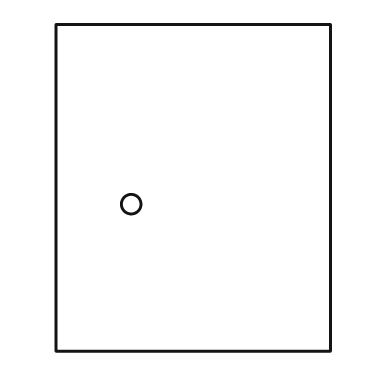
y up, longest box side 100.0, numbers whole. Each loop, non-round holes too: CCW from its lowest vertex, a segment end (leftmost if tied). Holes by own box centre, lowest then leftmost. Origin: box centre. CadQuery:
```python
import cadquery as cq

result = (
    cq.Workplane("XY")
    .moveTo(-42.0, -50.0)
    .lineTo(42.0, -50.0)
    .lineTo(42.0, 50.0)
    .lineTo(-42.0, 50.0)
    .close()
    .moveTo(-19.0, -5.0)
    .circle(3.0)
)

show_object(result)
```